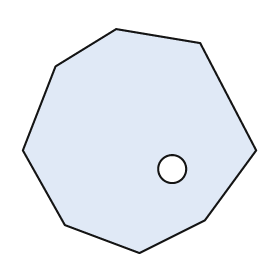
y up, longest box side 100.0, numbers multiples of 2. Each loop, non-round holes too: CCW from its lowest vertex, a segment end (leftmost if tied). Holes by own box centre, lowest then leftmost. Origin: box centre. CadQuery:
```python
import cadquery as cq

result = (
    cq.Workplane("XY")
    .moveTo(0.0, -48.0)
    .lineTo(28.0, -34.0)
    .lineTo(50.0, -4.0)
    .lineTo(26.0, 42.0)
    .lineTo(-10.0, 48.0)
    .lineTo(-36.0, 32.0)
    .lineTo(-50.0, -4.0)
    .lineTo(-32.0, -36.0)
    .close()
    .moveTo(14.0, -12.0)
    .circle(6.0)
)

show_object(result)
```